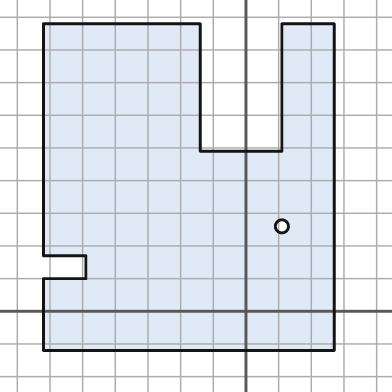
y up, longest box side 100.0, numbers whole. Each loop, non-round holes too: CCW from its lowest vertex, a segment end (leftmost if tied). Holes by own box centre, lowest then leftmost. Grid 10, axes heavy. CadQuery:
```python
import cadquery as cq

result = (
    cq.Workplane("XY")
    .moveTo(-62.0, -12.0)
    .lineTo(27.0, -12.0)
    .lineTo(27.0, 88.0)
    .lineTo(11.0, 88.0)
    .lineTo(11.0, 49.0)
    .lineTo(-14.0, 49.0)
    .lineTo(-14.0, 88.0)
    .lineTo(-62.0, 88.0)
    .lineTo(-62.0, 17.0)
    .lineTo(-49.0, 17.0)
    .lineTo(-49.0, 10.0)
    .lineTo(-62.0, 10.0)
    .close()
    .moveTo(11.0, 26.0)
    .circle(2.0)
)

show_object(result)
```